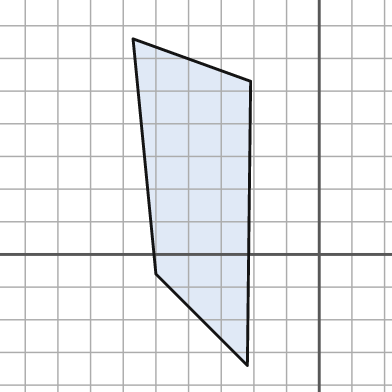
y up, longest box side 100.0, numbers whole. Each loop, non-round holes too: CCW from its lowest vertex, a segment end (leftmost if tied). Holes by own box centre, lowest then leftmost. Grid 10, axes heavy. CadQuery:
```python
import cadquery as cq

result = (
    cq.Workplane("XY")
    .moveTo(-22.0, -34.0)
    .lineTo(-21.0, 53.0)
    .lineTo(-57.0, 66.0)
    .lineTo(-50.0, -6.0)
    .close()
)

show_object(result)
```